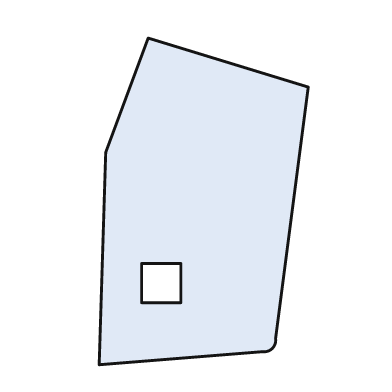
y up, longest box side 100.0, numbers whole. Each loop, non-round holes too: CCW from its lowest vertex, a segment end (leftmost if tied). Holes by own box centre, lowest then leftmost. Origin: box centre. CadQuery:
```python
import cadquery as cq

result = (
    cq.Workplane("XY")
    .moveTo(-32.0, -50.0)
    .lineTo(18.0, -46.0)
    .threePointArc((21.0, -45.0), (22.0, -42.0))
    .lineTo(32.0, 35.0)
    .lineTo(-17.0, 50.0)
    .lineTo(-30.0, 15.0)
    .close()
    .moveTo(-19.0, -31.0)
    .lineTo(-7.0, -31.0)
    .lineTo(-7.0, -19.0)
    .lineTo(-19.0, -19.0)
    .close()
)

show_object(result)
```